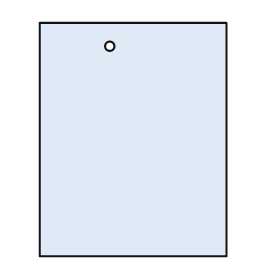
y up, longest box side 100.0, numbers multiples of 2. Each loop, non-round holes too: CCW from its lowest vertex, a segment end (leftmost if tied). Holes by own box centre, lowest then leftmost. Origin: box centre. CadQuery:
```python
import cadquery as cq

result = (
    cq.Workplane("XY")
    .moveTo(-40.0, -50.0)
    .lineTo(40.0, -50.0)
    .lineTo(40.0, 50.0)
    .lineTo(-40.0, 50.0)
    .close()
    .moveTo(-10.0, 40.0)
    .circle(2.0)
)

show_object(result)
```